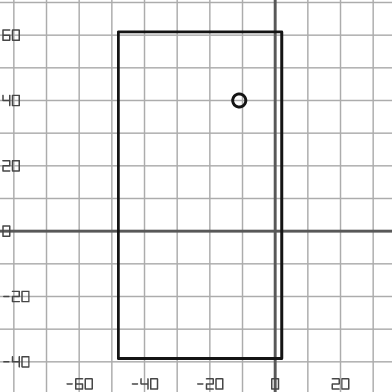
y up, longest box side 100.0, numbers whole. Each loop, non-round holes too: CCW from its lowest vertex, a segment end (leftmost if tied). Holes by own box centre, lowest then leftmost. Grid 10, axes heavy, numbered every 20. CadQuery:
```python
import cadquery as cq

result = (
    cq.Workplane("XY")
    .moveTo(-48.0, -39.0)
    .lineTo(2.0, -39.0)
    .lineTo(2.0, 61.0)
    .lineTo(-48.0, 61.0)
    .close()
    .moveTo(-11.0, 40.0)
    .circle(2.0)
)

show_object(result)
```